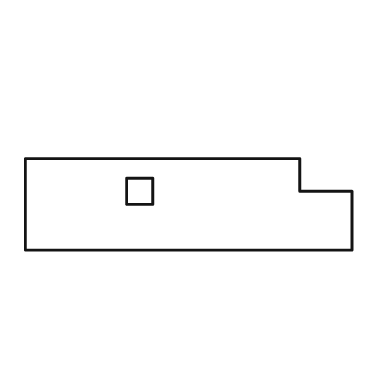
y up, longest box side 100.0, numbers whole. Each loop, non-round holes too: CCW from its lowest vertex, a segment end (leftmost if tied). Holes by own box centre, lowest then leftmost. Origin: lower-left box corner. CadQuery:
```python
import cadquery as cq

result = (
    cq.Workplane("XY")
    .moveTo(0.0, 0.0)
    .lineTo(100.0, 0.0)
    .lineTo(100.0, 18.0)
    .lineTo(84.0, 18.0)
    .lineTo(84.0, 28.0)
    .lineTo(0.0, 28.0)
    .close()
    .moveTo(31.0, 14.0)
    .lineTo(39.0, 14.0)
    .lineTo(39.0, 22.0)
    .lineTo(31.0, 22.0)
    .close()
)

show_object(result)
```